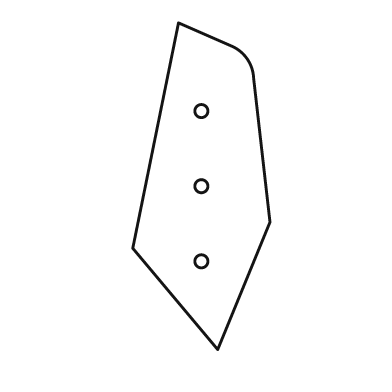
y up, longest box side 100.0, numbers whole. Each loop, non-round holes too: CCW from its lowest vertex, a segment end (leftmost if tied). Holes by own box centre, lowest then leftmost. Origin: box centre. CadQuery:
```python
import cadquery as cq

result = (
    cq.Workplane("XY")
    .moveTo(5.0, -50.0)
    .lineTo(21.0, -11.0)
    .lineTo(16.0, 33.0)
    .threePointArc((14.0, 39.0), (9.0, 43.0))
    .lineTo(-7.0, 50.0)
    .lineTo(-21.0, -19.0)
    .close()
    .moveTo(0.0, -23.0)
    .circle(2.0)
    .moveTo(0.0, 0.0)
    .circle(2.0)
    .moveTo(0.0, 23.0)
    .circle(2.0)
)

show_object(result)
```